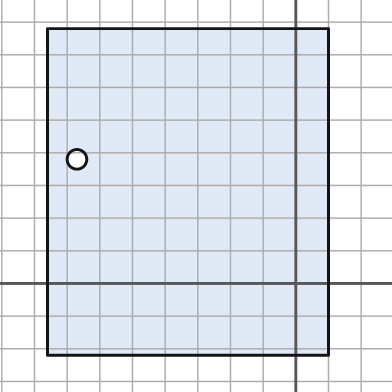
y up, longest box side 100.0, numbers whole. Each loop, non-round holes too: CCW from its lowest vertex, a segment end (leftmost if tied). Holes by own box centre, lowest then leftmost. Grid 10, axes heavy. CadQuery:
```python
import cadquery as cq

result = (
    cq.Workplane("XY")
    .moveTo(-76.0, -22.0)
    .lineTo(10.0, -22.0)
    .lineTo(10.0, 78.0)
    .lineTo(-76.0, 78.0)
    .close()
    .moveTo(-67.0, 38.0)
    .circle(3.0)
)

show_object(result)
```